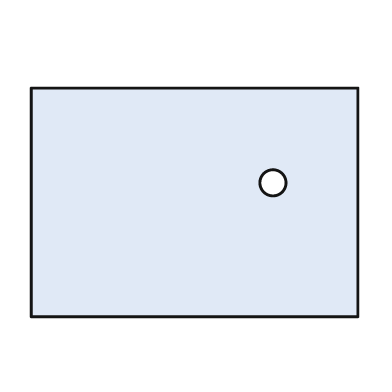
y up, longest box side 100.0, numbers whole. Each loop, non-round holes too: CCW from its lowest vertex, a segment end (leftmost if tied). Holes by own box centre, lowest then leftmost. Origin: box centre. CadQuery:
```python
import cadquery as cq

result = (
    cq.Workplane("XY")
    .moveTo(-50.0, -35.0)
    .lineTo(50.0, -35.0)
    .lineTo(50.0, 35.0)
    .lineTo(-50.0, 35.0)
    .close()
    .moveTo(24.0, 6.0)
    .circle(4.0)
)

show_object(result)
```